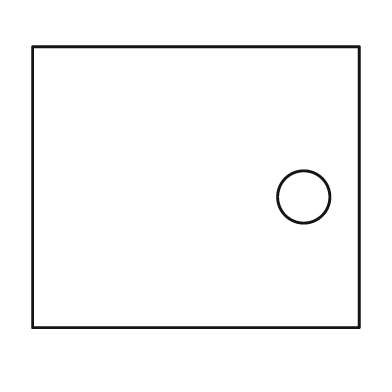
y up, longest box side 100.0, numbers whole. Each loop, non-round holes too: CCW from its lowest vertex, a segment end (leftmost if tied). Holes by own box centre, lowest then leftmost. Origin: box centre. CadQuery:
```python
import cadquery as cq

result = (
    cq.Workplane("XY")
    .moveTo(-50.0, -43.0)
    .lineTo(50.0, -43.0)
    .lineTo(50.0, 43.0)
    .lineTo(-50.0, 43.0)
    .close()
    .moveTo(33.0, -3.0)
    .circle(8.0)
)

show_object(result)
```